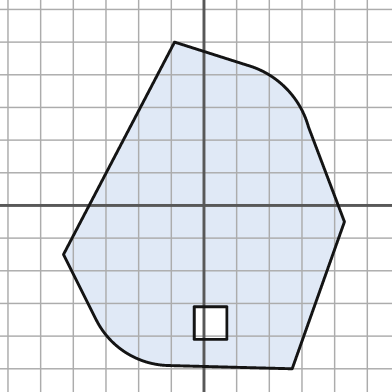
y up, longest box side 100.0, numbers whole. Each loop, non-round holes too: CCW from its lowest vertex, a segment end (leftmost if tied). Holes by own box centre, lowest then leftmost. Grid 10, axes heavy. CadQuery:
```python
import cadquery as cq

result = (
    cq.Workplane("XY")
    .moveTo(27.0, -50.0)
    .lineTo(43.0, -5.0)
    .lineTo(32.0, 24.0)
    .threePointArc((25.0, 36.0), (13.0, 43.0))
    .lineTo(-9.0, 50.0)
    .lineTo(-43.0, -15.0)
    .lineTo(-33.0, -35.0)
    .threePointArc((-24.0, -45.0), (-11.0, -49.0))
    .close()
    .moveTo(-3.0, -41.0)
    .lineTo(7.0, -41.0)
    .lineTo(7.0, -31.0)
    .lineTo(-3.0, -31.0)
    .close()
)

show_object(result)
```